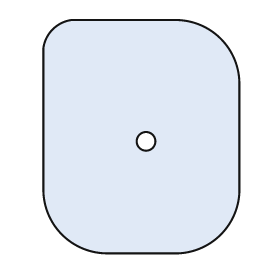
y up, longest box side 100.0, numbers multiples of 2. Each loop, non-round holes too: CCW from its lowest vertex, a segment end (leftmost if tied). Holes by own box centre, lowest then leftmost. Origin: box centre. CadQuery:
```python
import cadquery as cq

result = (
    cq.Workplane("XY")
    .moveTo(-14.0, -50.0)
    .lineTo(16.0, -50.0)
    .threePointArc((34.0, -42.0), (42.0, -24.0))
    .lineTo(42.0, 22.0)
    .threePointArc((34.0, 42.0), (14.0, 50.0))
    .lineTo(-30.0, 50.0)
    .threePointArc((-38.0, 46.0), (-42.0, 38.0))
    .lineTo(-42.0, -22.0)
    .threePointArc((-34.0, -42.0), (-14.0, -50.0))
    .close()
    .moveTo(2.0, -2.0)
    .circle(4.0)
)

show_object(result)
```